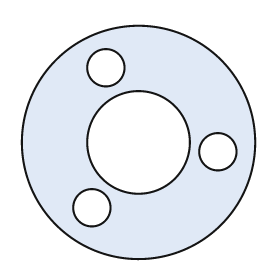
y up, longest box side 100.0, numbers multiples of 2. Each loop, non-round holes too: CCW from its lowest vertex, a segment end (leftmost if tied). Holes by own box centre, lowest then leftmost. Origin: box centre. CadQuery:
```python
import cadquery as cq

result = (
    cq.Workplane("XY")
    .moveTo(0.0, 0.0)
    .circle(50.0)
    .moveTo(-20.0, -28.0)
    .circle(8.0)
    .moveTo(34.0, -4.0)
    .circle(8.0)
    .moveTo(0.0, 0.0)
    .circle(22.0)
    .moveTo(-14.0, 32.0)
    .circle(8.0)
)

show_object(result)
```